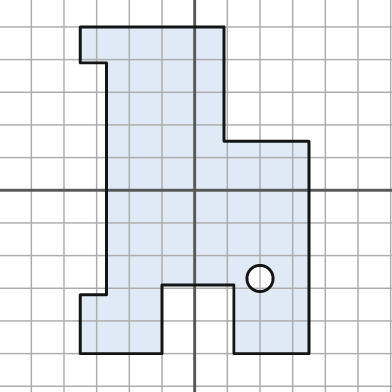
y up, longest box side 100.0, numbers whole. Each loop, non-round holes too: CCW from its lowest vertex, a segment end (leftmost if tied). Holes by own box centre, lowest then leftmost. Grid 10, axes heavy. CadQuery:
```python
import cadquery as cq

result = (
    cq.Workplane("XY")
    .moveTo(-35.0, -50.0)
    .lineTo(-10.0, -50.0)
    .lineTo(-10.0, -29.0)
    .lineTo(12.0, -29.0)
    .lineTo(12.0, -50.0)
    .lineTo(35.0, -50.0)
    .lineTo(35.0, 15.0)
    .lineTo(9.0, 15.0)
    .lineTo(9.0, 50.0)
    .lineTo(-35.0, 50.0)
    .lineTo(-35.0, 39.0)
    .lineTo(-27.0, 39.0)
    .lineTo(-27.0, -32.0)
    .lineTo(-35.0, -32.0)
    .close()
    .moveTo(20.0, -27.0)
    .circle(4.0)
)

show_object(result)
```